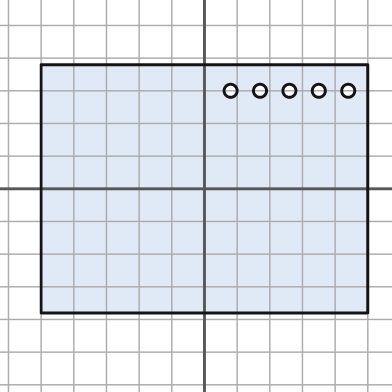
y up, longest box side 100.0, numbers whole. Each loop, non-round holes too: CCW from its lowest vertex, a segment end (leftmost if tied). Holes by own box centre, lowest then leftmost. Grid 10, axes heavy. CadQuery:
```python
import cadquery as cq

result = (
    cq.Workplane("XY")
    .moveTo(-50.0, -38.0)
    .lineTo(50.0, -38.0)
    .lineTo(50.0, 38.0)
    .lineTo(-50.0, 38.0)
    .close()
    .moveTo(8.0, 30.0)
    .circle(2.0)
    .moveTo(17.0, 30.0)
    .circle(2.0)
    .moveTo(26.0, 30.0)
    .circle(2.0)
    .moveTo(35.0, 30.0)
    .circle(2.0)
    .moveTo(44.0, 30.0)
    .circle(2.0)
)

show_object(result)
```